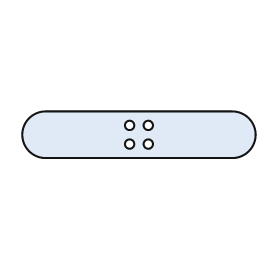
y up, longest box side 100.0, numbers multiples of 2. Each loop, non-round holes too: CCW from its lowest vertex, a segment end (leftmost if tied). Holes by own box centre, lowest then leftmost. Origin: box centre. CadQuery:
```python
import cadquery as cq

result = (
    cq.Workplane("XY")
    .moveTo(-40.0, -10.0)
    .lineTo(40.0, -10.0)
    .threePointArc((50.0, 0.0), (40.0, 10.0))
    .lineTo(-40.0, 10.0)
    .threePointArc((-50.0, 0.0), (-40.0, -10.0))
    .close()
    .moveTo(-4.0, -4.0)
    .circle(2.0)
    .moveTo(4.0, -4.0)
    .circle(2.0)
    .moveTo(-4.0, 4.0)
    .circle(2.0)
    .moveTo(4.0, 4.0)
    .circle(2.0)
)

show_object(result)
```